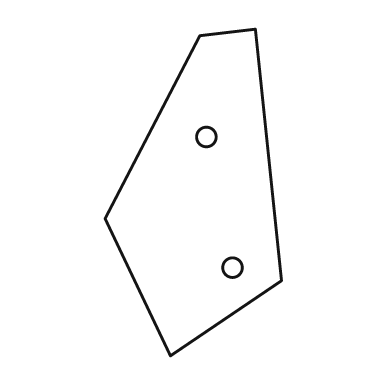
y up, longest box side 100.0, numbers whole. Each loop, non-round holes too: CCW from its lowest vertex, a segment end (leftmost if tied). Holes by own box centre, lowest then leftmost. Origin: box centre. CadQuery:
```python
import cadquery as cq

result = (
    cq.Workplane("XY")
    .moveTo(-7.0, -50.0)
    .lineTo(27.0, -27.0)
    .lineTo(19.0, 50.0)
    .lineTo(2.0, 48.0)
    .lineTo(-27.0, -8.0)
    .close()
    .moveTo(12.0, -23.0)
    .circle(3.0)
    .moveTo(4.0, 17.0)
    .circle(3.0)
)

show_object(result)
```